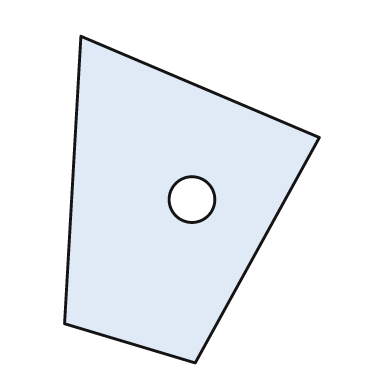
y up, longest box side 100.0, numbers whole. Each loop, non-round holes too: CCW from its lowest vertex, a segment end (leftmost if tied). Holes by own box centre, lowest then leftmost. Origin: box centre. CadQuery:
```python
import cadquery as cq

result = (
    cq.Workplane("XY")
    .moveTo(1.0, -50.0)
    .lineTo(39.0, 19.0)
    .lineTo(-34.0, 50.0)
    .lineTo(-39.0, -38.0)
    .close()
    .moveTo(0.0, 0.0)
    .circle(7.0)
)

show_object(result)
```